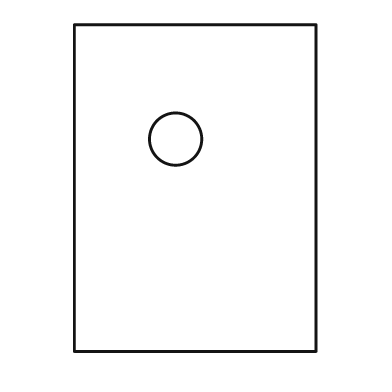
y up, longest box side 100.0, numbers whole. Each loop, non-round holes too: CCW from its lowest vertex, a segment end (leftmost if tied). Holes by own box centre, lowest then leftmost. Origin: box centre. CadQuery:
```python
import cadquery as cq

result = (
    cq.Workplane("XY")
    .moveTo(-37.0, -50.0)
    .lineTo(37.0, -50.0)
    .lineTo(37.0, 50.0)
    .lineTo(-37.0, 50.0)
    .close()
    .moveTo(-6.0, 15.0)
    .circle(8.0)
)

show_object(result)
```